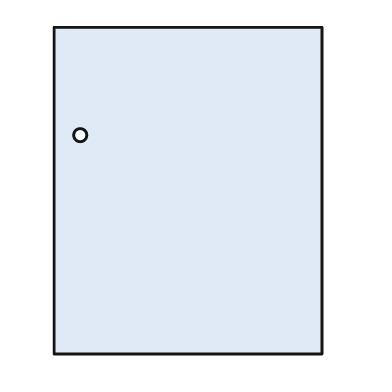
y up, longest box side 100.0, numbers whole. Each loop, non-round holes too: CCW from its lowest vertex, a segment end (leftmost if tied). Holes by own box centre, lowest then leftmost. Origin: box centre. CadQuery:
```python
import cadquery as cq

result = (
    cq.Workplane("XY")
    .moveTo(-41.0, -50.0)
    .lineTo(41.0, -50.0)
    .lineTo(41.0, 50.0)
    .lineTo(-41.0, 50.0)
    .close()
    .moveTo(-33.0, 17.0)
    .circle(2.0)
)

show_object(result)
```